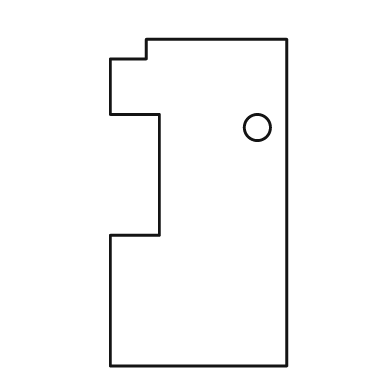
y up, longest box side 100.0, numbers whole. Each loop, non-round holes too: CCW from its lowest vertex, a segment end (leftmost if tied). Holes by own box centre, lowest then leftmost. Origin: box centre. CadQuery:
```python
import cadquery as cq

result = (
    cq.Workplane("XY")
    .moveTo(-27.0, -50.0)
    .lineTo(27.0, -50.0)
    .lineTo(27.0, 50.0)
    .lineTo(-16.0, 50.0)
    .lineTo(-16.0, 44.0)
    .lineTo(-27.0, 44.0)
    .lineTo(-27.0, 27.0)
    .lineTo(-12.0, 27.0)
    .lineTo(-12.0, -10.0)
    .lineTo(-27.0, -10.0)
    .close()
    .moveTo(18.0, 23.0)
    .circle(4.0)
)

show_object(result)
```